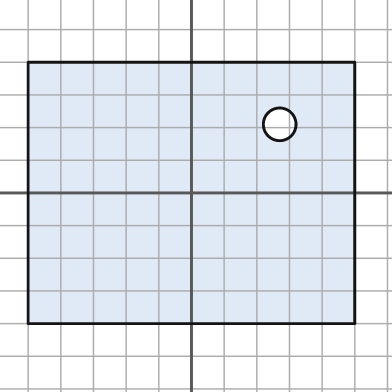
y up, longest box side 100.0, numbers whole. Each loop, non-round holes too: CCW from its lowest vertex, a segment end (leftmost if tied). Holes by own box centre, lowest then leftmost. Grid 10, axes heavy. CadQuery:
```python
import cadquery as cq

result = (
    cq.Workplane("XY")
    .moveTo(-50.0, -40.0)
    .lineTo(50.0, -40.0)
    .lineTo(50.0, 40.0)
    .lineTo(-50.0, 40.0)
    .close()
    .moveTo(27.0, 21.0)
    .circle(5.0)
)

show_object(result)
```